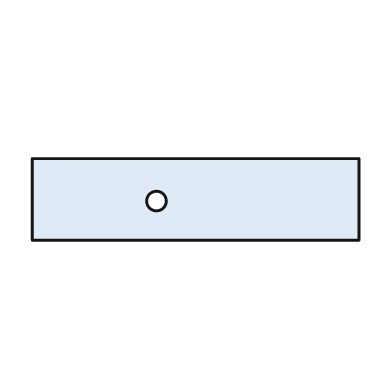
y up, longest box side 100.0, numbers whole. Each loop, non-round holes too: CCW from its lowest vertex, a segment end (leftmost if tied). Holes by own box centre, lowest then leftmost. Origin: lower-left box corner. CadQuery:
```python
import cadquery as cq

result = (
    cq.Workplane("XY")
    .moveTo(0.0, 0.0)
    .lineTo(100.0, 0.0)
    .lineTo(100.0, 25.0)
    .lineTo(0.0, 25.0)
    .close()
    .moveTo(38.0, 12.0)
    .circle(3.0)
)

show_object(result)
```